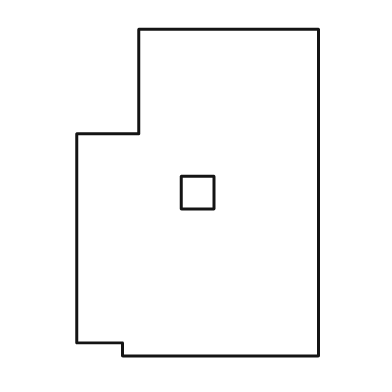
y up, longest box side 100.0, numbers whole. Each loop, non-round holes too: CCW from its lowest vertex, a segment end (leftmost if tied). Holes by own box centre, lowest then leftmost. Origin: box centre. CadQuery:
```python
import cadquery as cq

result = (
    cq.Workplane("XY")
    .moveTo(-23.0, -50.0)
    .lineTo(37.0, -50.0)
    .lineTo(37.0, 50.0)
    .lineTo(-18.0, 50.0)
    .lineTo(-18.0, 18.0)
    .lineTo(-37.0, 18.0)
    .lineTo(-37.0, -46.0)
    .lineTo(-23.0, -46.0)
    .close()
    .moveTo(-5.0, -5.0)
    .lineTo(5.0, -5.0)
    .lineTo(5.0, 5.0)
    .lineTo(-5.0, 5.0)
    .close()
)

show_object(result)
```